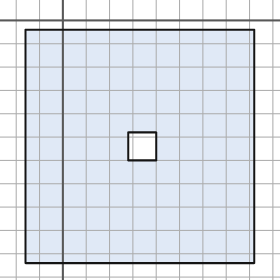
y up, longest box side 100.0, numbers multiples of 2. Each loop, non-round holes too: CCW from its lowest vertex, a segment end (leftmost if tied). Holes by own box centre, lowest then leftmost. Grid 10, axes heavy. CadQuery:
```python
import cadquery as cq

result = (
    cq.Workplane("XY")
    .moveTo(-16.0, -104.0)
    .lineTo(82.0, -104.0)
    .lineTo(82.0, -4.0)
    .lineTo(-16.0, -4.0)
    .close()
    .moveTo(28.0, -60.0)
    .lineTo(40.0, -60.0)
    .lineTo(40.0, -48.0)
    .lineTo(28.0, -48.0)
    .close()
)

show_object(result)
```